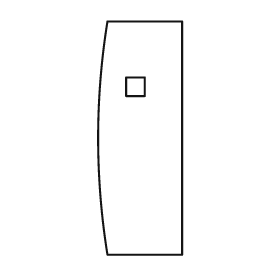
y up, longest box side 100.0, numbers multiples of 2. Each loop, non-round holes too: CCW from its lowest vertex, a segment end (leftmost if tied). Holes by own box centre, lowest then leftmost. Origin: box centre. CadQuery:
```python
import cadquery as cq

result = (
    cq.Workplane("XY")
    .moveTo(-14.0, -50.0)
    .lineTo(18.0, -50.0)
    .lineTo(18.0, 50.0)
    .lineTo(-14.0, 50.0)
    .threePointArc((-18.0, 0.0), (-14.0, -50.0))
    .close()
    .moveTo(-6.0, 18.0)
    .lineTo(2.0, 18.0)
    .lineTo(2.0, 26.0)
    .lineTo(-6.0, 26.0)
    .close()
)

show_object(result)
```